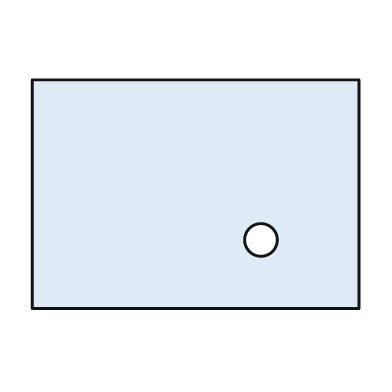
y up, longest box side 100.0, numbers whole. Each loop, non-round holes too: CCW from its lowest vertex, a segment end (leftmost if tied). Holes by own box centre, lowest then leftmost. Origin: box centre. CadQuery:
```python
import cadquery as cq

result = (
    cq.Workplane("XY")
    .moveTo(-50.0, -35.0)
    .lineTo(50.0, -35.0)
    .lineTo(50.0, 35.0)
    .lineTo(-50.0, 35.0)
    .close()
    .moveTo(20.0, -14.0)
    .circle(5.0)
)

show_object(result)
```